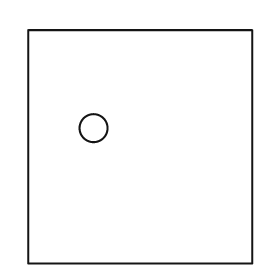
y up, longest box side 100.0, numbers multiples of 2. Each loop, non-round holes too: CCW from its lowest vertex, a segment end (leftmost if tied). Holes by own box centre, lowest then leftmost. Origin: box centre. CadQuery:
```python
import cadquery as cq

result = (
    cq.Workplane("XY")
    .moveTo(-48.0, -50.0)
    .lineTo(48.0, -50.0)
    .lineTo(48.0, 50.0)
    .lineTo(-48.0, 50.0)
    .close()
    .moveTo(-20.0, 8.0)
    .circle(6.0)
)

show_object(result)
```